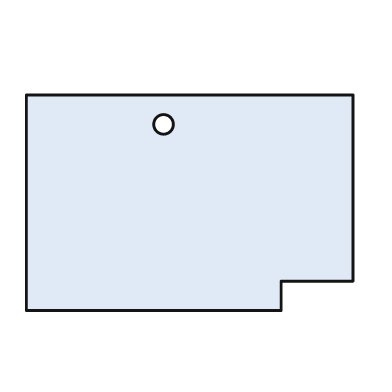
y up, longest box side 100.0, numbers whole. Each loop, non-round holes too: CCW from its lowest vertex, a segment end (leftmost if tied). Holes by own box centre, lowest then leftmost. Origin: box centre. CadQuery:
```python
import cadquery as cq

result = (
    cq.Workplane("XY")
    .moveTo(-50.0, -33.0)
    .lineTo(28.0, -33.0)
    .lineTo(28.0, -24.0)
    .lineTo(50.0, -24.0)
    .lineTo(50.0, 33.0)
    .lineTo(-50.0, 33.0)
    .close()
    .moveTo(-8.0, 24.0)
    .circle(3.0)
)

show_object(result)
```